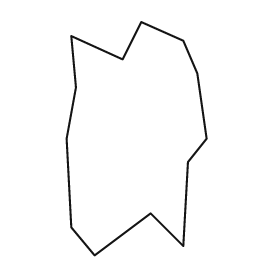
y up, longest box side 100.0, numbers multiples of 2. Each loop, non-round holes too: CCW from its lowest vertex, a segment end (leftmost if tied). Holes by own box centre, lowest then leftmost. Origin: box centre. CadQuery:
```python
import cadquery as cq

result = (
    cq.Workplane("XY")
    .moveTo(-18.0, -50.0)
    .lineTo(6.0, -32.0)
    .lineTo(20.0, -46.0)
    .lineTo(22.0, -10.0)
    .lineTo(30.0, 0.0)
    .lineTo(26.0, 28.0)
    .lineTo(20.0, 42.0)
    .lineTo(2.0, 50.0)
    .lineTo(-6.0, 34.0)
    .lineTo(-28.0, 44.0)
    .lineTo(-26.0, 22.0)
    .lineTo(-30.0, 0.0)
    .lineTo(-28.0, -38.0)
    .close()
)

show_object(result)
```